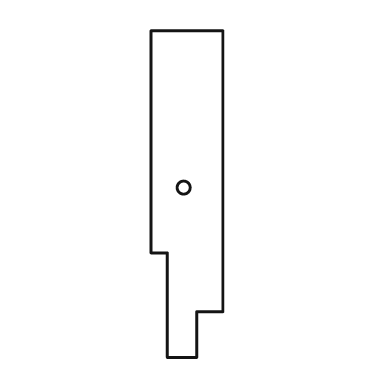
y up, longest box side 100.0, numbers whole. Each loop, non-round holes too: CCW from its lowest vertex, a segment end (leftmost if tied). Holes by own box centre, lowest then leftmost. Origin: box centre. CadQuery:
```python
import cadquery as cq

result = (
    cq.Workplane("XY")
    .moveTo(-6.0, -50.0)
    .lineTo(3.0, -50.0)
    .lineTo(3.0, -36.0)
    .lineTo(11.0, -36.0)
    .lineTo(11.0, 50.0)
    .lineTo(-11.0, 50.0)
    .lineTo(-11.0, -18.0)
    .lineTo(-6.0, -18.0)
    .close()
    .moveTo(-1.0, 2.0)
    .circle(2.0)
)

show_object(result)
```